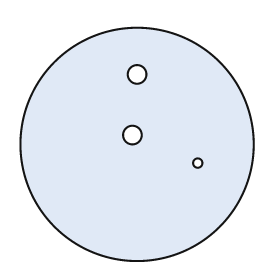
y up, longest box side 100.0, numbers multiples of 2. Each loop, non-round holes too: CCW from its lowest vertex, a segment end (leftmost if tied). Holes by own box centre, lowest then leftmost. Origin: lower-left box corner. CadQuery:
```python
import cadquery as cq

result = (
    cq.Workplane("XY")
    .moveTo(50.0, 50.0)
    .circle(50.0)
    .moveTo(76.0, 42.0)
    .circle(2.0)
    .moveTo(48.0, 54.0)
    .circle(4.0)
    .moveTo(50.0, 80.0)
    .circle(4.0)
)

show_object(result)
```